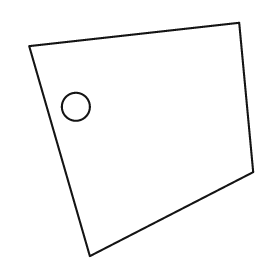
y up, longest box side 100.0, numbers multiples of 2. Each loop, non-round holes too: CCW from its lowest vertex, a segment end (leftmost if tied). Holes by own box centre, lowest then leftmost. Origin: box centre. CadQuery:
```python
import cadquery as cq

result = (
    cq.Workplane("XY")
    .moveTo(-22.0, -50.0)
    .lineTo(48.0, -14.0)
    .lineTo(42.0, 50.0)
    .lineTo(-48.0, 40.0)
    .close()
    .moveTo(-28.0, 14.0)
    .circle(6.0)
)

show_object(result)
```